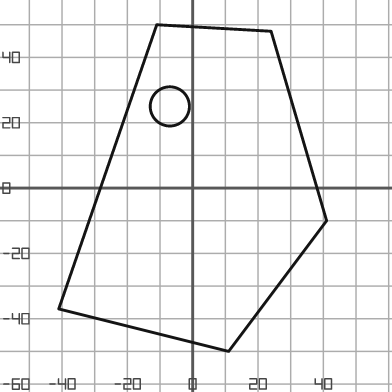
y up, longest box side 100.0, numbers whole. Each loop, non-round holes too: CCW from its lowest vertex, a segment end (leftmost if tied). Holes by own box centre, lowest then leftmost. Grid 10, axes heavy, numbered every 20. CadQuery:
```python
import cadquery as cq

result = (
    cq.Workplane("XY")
    .moveTo(11.0, -50.0)
    .lineTo(41.0, -10.0)
    .lineTo(24.0, 48.0)
    .lineTo(-11.0, 50.0)
    .lineTo(-41.0, -37.0)
    .close()
    .moveTo(-7.0, 25.0)
    .circle(6.0)
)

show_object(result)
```